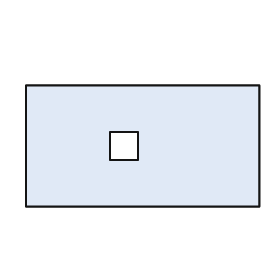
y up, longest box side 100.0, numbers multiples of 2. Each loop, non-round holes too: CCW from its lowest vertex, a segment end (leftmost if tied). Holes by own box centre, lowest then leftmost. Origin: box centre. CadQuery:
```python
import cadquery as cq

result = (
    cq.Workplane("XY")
    .moveTo(-50.0, -26.0)
    .lineTo(50.0, -26.0)
    .lineTo(50.0, 26.0)
    .lineTo(-50.0, 26.0)
    .close()
    .moveTo(-14.0, -6.0)
    .lineTo(-2.0, -6.0)
    .lineTo(-2.0, 6.0)
    .lineTo(-14.0, 6.0)
    .close()
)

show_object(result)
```